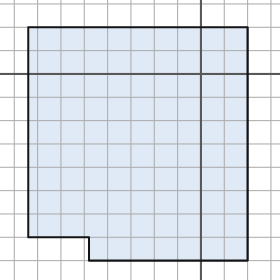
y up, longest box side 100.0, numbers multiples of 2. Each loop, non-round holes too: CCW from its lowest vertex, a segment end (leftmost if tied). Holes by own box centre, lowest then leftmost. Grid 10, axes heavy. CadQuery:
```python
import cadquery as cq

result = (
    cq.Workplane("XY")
    .moveTo(-48.0, -80.0)
    .lineTo(20.0, -80.0)
    .lineTo(20.0, 20.0)
    .lineTo(-74.0, 20.0)
    .lineTo(-74.0, -70.0)
    .lineTo(-48.0, -70.0)
    .close()
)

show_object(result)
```